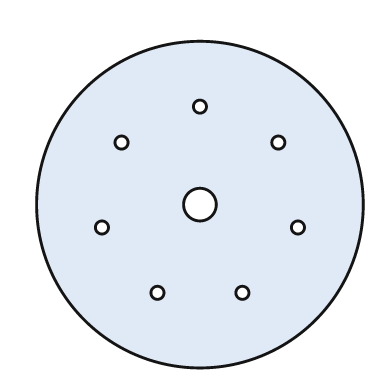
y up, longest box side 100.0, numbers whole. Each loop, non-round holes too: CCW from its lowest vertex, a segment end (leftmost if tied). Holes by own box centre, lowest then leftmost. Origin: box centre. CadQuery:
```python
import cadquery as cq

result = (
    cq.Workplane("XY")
    .moveTo(0.0, 0.0)
    .circle(50.0)
    .moveTo(-13.0, -27.0)
    .circle(2.0)
    .moveTo(13.0, -27.0)
    .circle(2.0)
    .moveTo(-30.0, -7.0)
    .circle(2.0)
    .moveTo(30.0, -7.0)
    .circle(2.0)
    .moveTo(0.0, 0.0)
    .circle(5.0)
    .moveTo(-24.0, 19.0)
    .circle(2.0)
    .moveTo(24.0, 19.0)
    .circle(2.0)
    .moveTo(0.0, 30.0)
    .circle(2.0)
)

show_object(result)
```